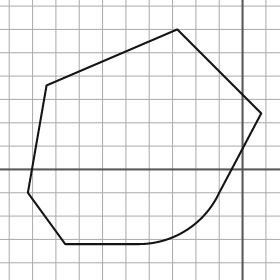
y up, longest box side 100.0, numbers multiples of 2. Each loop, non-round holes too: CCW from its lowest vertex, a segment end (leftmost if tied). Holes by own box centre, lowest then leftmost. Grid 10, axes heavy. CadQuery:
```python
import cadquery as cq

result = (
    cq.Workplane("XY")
    .moveTo(-76.0, -32.0)
    .lineTo(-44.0, -32.0)
    .threePointArc((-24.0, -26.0), (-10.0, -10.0))
    .lineTo(8.0, 24.0)
    .lineTo(-28.0, 60.0)
    .lineTo(-84.0, 36.0)
    .lineTo(-92.0, -10.0)
    .close()
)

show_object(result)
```